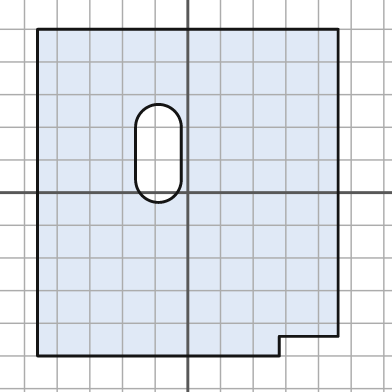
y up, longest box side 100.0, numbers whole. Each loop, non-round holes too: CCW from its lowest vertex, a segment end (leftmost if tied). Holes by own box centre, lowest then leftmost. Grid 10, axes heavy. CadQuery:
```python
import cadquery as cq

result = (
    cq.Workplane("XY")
    .moveTo(-46.0, -50.0)
    .lineTo(28.0, -50.0)
    .lineTo(28.0, -44.0)
    .lineTo(46.0, -44.0)
    .lineTo(46.0, 50.0)
    .lineTo(-46.0, 50.0)
    .close()
    .moveTo(-16.0, 4.0)
    .threePointArc((-9.0, -3.0), (-2.0, 4.0))
    .lineTo(-2.0, 20.0)
    .threePointArc((-9.0, 27.0), (-16.0, 20.0))
    .close()
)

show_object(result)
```